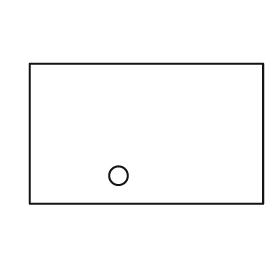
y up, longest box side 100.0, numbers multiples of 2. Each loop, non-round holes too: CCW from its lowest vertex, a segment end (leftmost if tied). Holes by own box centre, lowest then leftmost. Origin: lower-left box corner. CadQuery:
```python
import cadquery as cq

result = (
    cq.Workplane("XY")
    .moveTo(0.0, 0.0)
    .lineTo(100.0, 0.0)
    .lineTo(100.0, 60.0)
    .lineTo(0.0, 60.0)
    .close()
    .moveTo(38.0, 12.0)
    .circle(4.0)
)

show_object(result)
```